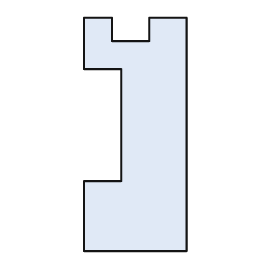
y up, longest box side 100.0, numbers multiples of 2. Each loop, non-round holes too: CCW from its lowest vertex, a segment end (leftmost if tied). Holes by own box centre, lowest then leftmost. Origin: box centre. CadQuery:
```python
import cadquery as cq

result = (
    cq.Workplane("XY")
    .moveTo(-22.0, -50.0)
    .lineTo(22.0, -50.0)
    .lineTo(22.0, 50.0)
    .lineTo(6.0, 50.0)
    .lineTo(6.0, 40.0)
    .lineTo(-10.0, 40.0)
    .lineTo(-10.0, 50.0)
    .lineTo(-22.0, 50.0)
    .lineTo(-22.0, 28.0)
    .lineTo(-6.0, 28.0)
    .lineTo(-6.0, -20.0)
    .lineTo(-22.0, -20.0)
    .close()
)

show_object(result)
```